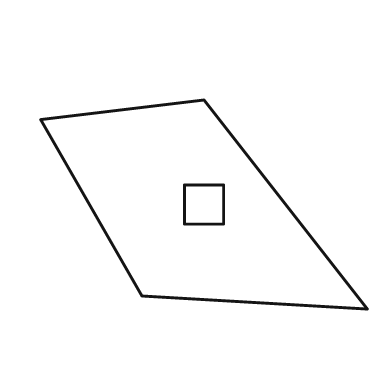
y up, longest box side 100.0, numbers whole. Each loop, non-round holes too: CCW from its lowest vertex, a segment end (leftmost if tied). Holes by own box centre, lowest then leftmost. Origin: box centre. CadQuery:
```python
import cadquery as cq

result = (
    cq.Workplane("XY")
    .moveTo(50.0, -32.0)
    .lineTo(0.0, 32.0)
    .lineTo(-50.0, 26.0)
    .lineTo(-19.0, -28.0)
    .close()
    .moveTo(-6.0, -6.0)
    .lineTo(6.0, -6.0)
    .lineTo(6.0, 6.0)
    .lineTo(-6.0, 6.0)
    .close()
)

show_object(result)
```